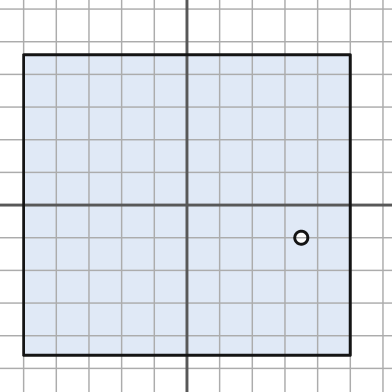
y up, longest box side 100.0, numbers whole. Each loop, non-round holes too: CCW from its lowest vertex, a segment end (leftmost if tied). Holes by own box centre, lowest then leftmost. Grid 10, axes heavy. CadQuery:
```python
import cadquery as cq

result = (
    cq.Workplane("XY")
    .moveTo(-50.0, -46.0)
    .lineTo(50.0, -46.0)
    .lineTo(50.0, 46.0)
    .lineTo(-50.0, 46.0)
    .close()
    .moveTo(35.0, -10.0)
    .circle(2.0)
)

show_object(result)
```